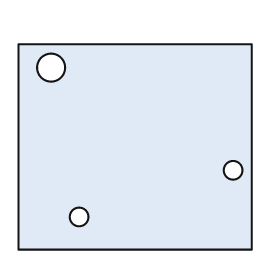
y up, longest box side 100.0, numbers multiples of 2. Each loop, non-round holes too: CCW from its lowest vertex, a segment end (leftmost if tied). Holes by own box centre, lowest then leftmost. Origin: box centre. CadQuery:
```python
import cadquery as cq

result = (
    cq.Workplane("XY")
    .moveTo(-50.0, -44.0)
    .lineTo(50.0, -44.0)
    .lineTo(50.0, 44.0)
    .lineTo(-50.0, 44.0)
    .close()
    .moveTo(-24.0, -30.0)
    .circle(4.0)
    .moveTo(42.0, -10.0)
    .circle(4.0)
    .moveTo(-36.0, 34.0)
    .circle(6.0)
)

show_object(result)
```